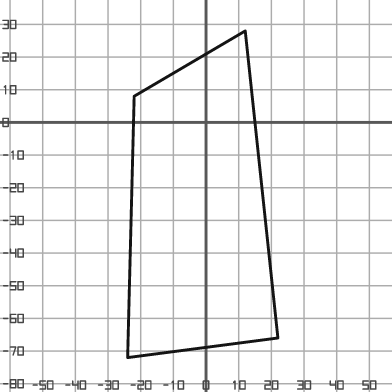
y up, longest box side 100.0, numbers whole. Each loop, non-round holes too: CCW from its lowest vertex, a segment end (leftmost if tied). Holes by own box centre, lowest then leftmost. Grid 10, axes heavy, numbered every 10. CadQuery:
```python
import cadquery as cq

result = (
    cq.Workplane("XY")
    .moveTo(-24.0, -72.0)
    .lineTo(22.0, -66.0)
    .lineTo(12.0, 28.0)
    .lineTo(-22.0, 8.0)
    .close()
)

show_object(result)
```